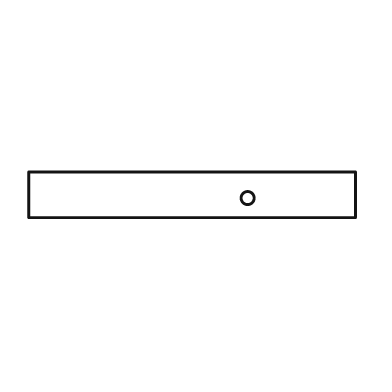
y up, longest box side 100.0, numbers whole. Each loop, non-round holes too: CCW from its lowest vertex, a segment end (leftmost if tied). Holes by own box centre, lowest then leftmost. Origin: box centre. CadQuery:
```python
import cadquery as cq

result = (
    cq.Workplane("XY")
    .moveTo(-50.0, -7.0)
    .lineTo(50.0, -7.0)
    .lineTo(50.0, 7.0)
    .lineTo(-50.0, 7.0)
    .close()
    .moveTo(17.0, -1.0)
    .circle(2.0)
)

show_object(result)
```